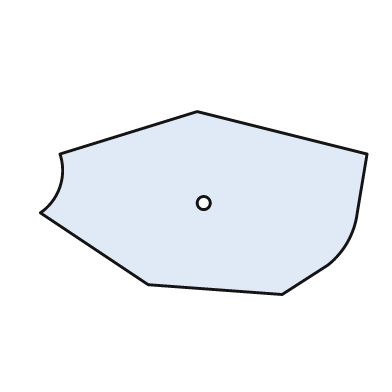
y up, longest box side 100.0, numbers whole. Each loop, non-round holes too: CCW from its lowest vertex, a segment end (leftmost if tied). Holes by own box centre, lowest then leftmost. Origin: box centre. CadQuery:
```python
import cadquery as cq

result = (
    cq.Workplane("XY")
    .moveTo(24.0, -28.0)
    .lineTo(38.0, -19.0)
    .threePointArc((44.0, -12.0), (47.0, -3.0))
    .lineTo(50.0, 15.0)
    .lineTo(-2.0, 28.0)
    .lineTo(-44.0, 15.0)
    .threePointArc((-44.0, 5.0), (-50.0, -3.0))
    .lineTo(-17.0, -25.0)
    .close()
    .moveTo(0.0, 0.0)
    .circle(2.0)
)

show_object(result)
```